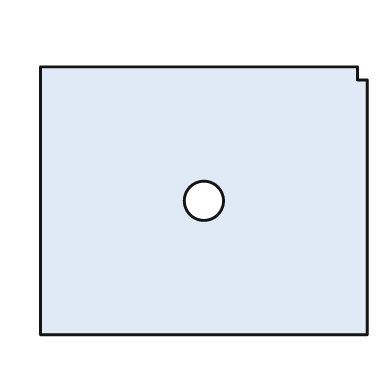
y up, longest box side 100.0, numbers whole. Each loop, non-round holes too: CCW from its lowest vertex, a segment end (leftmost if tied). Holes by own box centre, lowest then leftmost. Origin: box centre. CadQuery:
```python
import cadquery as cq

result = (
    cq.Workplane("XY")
    .moveTo(-50.0, -41.0)
    .lineTo(50.0, -41.0)
    .lineTo(50.0, 37.0)
    .lineTo(47.0, 37.0)
    .lineTo(47.0, 41.0)
    .lineTo(-50.0, 41.0)
    .close()
    .moveTo(0.0, 0.0)
    .circle(6.0)
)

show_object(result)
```